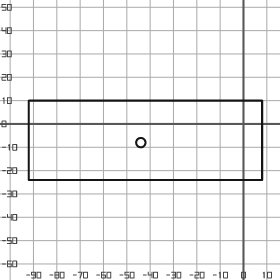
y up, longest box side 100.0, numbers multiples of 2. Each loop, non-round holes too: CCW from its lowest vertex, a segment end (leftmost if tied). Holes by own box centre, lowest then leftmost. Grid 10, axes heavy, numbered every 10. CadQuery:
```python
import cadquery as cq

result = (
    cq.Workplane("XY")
    .moveTo(-92.0, -24.0)
    .lineTo(8.0, -24.0)
    .lineTo(8.0, 10.0)
    .lineTo(-92.0, 10.0)
    .close()
    .moveTo(-44.0, -8.0)
    .circle(2.0)
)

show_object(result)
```